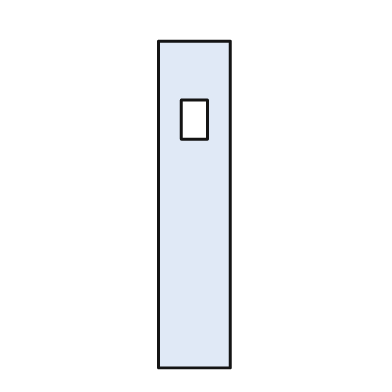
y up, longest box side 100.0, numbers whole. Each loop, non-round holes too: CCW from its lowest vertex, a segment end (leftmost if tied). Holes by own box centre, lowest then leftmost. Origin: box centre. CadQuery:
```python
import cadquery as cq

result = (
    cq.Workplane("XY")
    .moveTo(-11.0, -50.0)
    .lineTo(11.0, -50.0)
    .lineTo(11.0, 50.0)
    .lineTo(-11.0, 50.0)
    .close()
    .moveTo(-4.0, 20.0)
    .lineTo(4.0, 20.0)
    .lineTo(4.0, 32.0)
    .lineTo(-4.0, 32.0)
    .close()
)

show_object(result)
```